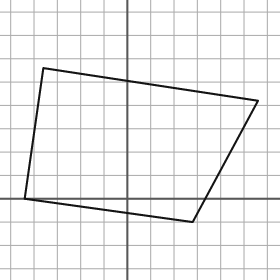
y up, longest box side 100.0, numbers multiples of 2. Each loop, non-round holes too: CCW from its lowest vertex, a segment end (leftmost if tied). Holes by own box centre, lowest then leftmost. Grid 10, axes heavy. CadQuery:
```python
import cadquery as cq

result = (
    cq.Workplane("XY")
    .moveTo(28.0, -10.0)
    .lineTo(56.0, 42.0)
    .lineTo(-36.0, 56.0)
    .lineTo(-44.0, 0.0)
    .close()
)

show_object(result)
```